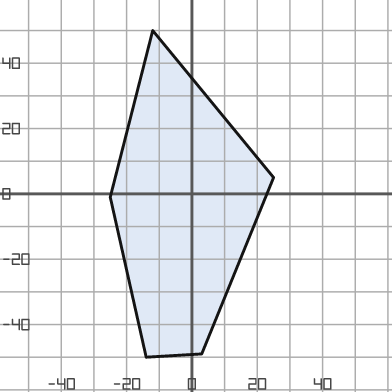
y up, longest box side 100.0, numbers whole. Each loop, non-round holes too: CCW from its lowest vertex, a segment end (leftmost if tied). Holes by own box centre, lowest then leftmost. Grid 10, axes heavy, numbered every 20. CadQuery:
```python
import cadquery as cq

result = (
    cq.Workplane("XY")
    .moveTo(-14.0, -50.0)
    .lineTo(3.0, -49.0)
    .lineTo(25.0, 5.0)
    .lineTo(-12.0, 50.0)
    .lineTo(-25.0, -1.0)
    .close()
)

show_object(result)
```